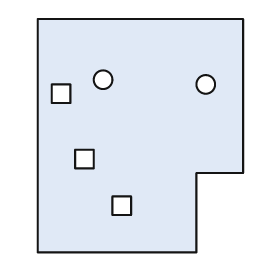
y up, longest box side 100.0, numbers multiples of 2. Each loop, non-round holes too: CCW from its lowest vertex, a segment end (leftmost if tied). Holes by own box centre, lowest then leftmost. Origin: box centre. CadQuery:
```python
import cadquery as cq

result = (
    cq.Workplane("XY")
    .moveTo(-44.0, -50.0)
    .lineTo(24.0, -50.0)
    .lineTo(24.0, -16.0)
    .lineTo(44.0, -16.0)
    .lineTo(44.0, 50.0)
    .lineTo(-44.0, 50.0)
    .close()
    .moveTo(-12.0, -34.0)
    .lineTo(-4.0, -34.0)
    .lineTo(-4.0, -26.0)
    .lineTo(-12.0, -26.0)
    .close()
    .moveTo(-28.0, -14.0)
    .lineTo(-20.0, -14.0)
    .lineTo(-20.0, -6.0)
    .lineTo(-28.0, -6.0)
    .close()
    .moveTo(-38.0, 14.0)
    .lineTo(-30.0, 14.0)
    .lineTo(-30.0, 22.0)
    .lineTo(-38.0, 22.0)
    .close()
    .moveTo(28.0, 22.0)
    .circle(4.0)
    .moveTo(-16.0, 24.0)
    .circle(4.0)
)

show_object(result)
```